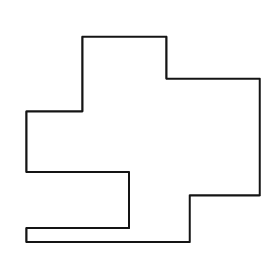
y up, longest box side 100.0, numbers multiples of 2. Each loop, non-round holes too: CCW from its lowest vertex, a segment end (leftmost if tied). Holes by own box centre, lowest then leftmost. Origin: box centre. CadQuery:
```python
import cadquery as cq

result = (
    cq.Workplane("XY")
    .moveTo(-50.0, -44.0)
    .lineTo(20.0, -44.0)
    .lineTo(20.0, -24.0)
    .lineTo(50.0, -24.0)
    .lineTo(50.0, 26.0)
    .lineTo(10.0, 26.0)
    .lineTo(10.0, 44.0)
    .lineTo(-26.0, 44.0)
    .lineTo(-26.0, 12.0)
    .lineTo(-50.0, 12.0)
    .lineTo(-50.0, -14.0)
    .lineTo(-6.0, -14.0)
    .lineTo(-6.0, -38.0)
    .lineTo(-50.0, -38.0)
    .close()
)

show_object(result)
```